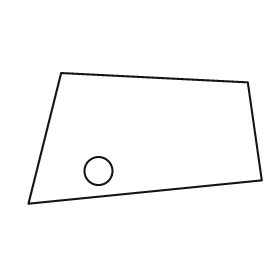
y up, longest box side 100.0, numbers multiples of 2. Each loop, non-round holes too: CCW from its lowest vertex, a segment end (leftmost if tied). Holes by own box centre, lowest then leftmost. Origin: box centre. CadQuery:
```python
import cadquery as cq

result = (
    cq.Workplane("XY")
    .moveTo(-50.0, -28.0)
    .lineTo(50.0, -18.0)
    .lineTo(44.0, 24.0)
    .lineTo(-36.0, 28.0)
    .close()
    .moveTo(-20.0, -14.0)
    .circle(6.0)
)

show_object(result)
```